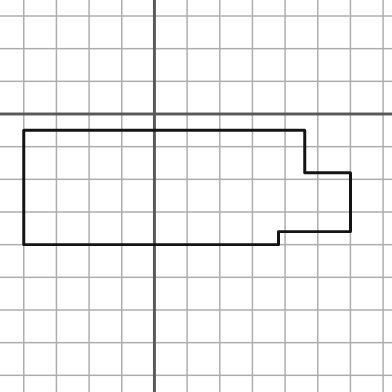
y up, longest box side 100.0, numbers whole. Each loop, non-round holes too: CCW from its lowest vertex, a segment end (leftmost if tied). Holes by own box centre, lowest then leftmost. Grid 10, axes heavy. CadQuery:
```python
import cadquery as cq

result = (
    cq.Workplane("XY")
    .moveTo(-40.0, -40.0)
    .lineTo(38.0, -40.0)
    .lineTo(38.0, -36.0)
    .lineTo(60.0, -36.0)
    .lineTo(60.0, -18.0)
    .lineTo(46.0, -18.0)
    .lineTo(46.0, -5.0)
    .lineTo(-40.0, -5.0)
    .close()
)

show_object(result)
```